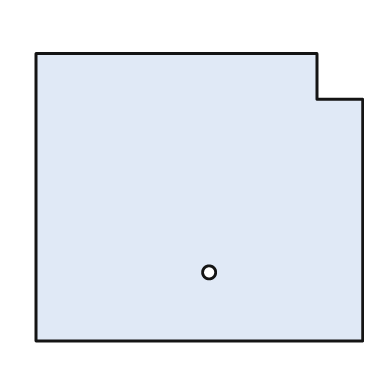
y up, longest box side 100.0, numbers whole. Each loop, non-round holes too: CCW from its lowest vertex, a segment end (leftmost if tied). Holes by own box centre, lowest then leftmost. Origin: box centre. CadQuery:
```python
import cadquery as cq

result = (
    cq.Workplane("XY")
    .moveTo(-50.0, -44.0)
    .lineTo(50.0, -44.0)
    .lineTo(50.0, 30.0)
    .lineTo(36.0, 30.0)
    .lineTo(36.0, 44.0)
    .lineTo(-50.0, 44.0)
    .close()
    .moveTo(3.0, -23.0)
    .circle(2.0)
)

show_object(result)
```